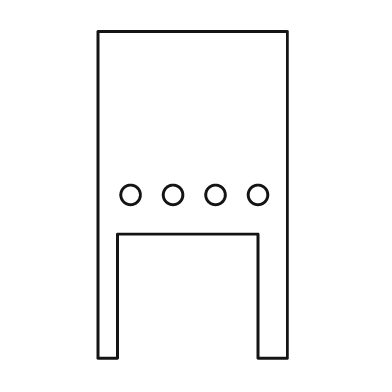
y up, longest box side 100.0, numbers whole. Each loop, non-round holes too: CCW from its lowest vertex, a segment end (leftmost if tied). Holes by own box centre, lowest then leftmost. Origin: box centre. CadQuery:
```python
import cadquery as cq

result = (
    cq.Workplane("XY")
    .moveTo(-29.0, -50.0)
    .lineTo(-23.0, -50.0)
    .lineTo(-23.0, -12.0)
    .lineTo(20.0, -12.0)
    .lineTo(20.0, -50.0)
    .lineTo(29.0, -50.0)
    .lineTo(29.0, 50.0)
    .lineTo(-29.0, 50.0)
    .close()
    .moveTo(-19.0, 0.0)
    .circle(3.0)
    .moveTo(-6.0, 0.0)
    .circle(3.0)
    .moveTo(7.0, 0.0)
    .circle(3.0)
    .moveTo(20.0, 0.0)
    .circle(3.0)
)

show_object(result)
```